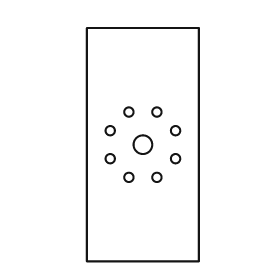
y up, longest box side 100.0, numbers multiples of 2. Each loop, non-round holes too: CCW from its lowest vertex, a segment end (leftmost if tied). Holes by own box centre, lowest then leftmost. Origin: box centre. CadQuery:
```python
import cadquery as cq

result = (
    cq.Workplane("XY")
    .moveTo(-24.0, -50.0)
    .lineTo(24.0, -50.0)
    .lineTo(24.0, 50.0)
    .lineTo(-24.0, 50.0)
    .close()
    .moveTo(-6.0, -14.0)
    .circle(2.0)
    .moveTo(6.0, -14.0)
    .circle(2.0)
    .moveTo(-14.0, -6.0)
    .circle(2.0)
    .moveTo(14.0, -6.0)
    .circle(2.0)
    .moveTo(0.0, 0.0)
    .circle(4.0)
    .moveTo(-14.0, 6.0)
    .circle(2.0)
    .moveTo(14.0, 6.0)
    .circle(2.0)
    .moveTo(-6.0, 14.0)
    .circle(2.0)
    .moveTo(6.0, 14.0)
    .circle(2.0)
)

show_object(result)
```